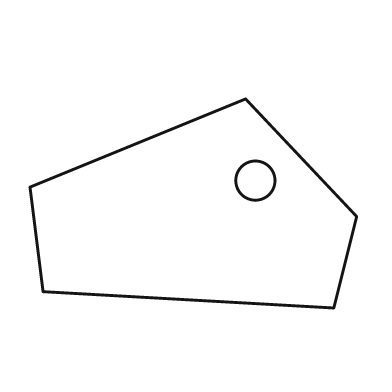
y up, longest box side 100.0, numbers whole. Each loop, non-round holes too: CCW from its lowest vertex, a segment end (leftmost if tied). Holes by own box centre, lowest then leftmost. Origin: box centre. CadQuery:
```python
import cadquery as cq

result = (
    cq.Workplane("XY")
    .moveTo(43.0, -32.0)
    .lineTo(50.0, -4.0)
    .lineTo(16.0, 32.0)
    .lineTo(-50.0, 5.0)
    .lineTo(-46.0, -27.0)
    .close()
    .moveTo(19.0, 7.0)
    .circle(6.0)
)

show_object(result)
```